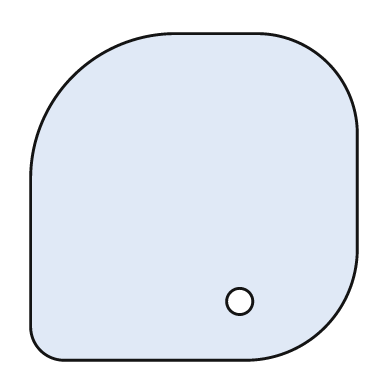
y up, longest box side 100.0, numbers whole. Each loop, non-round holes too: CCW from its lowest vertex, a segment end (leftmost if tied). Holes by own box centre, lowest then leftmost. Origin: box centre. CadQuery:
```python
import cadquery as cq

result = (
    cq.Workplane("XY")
    .moveTo(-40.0, -50.0)
    .lineTo(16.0, -50.0)
    .threePointArc((40.0, -40.0), (50.0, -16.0))
    .lineTo(50.0, 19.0)
    .threePointArc((41.0, 41.0), (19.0, 50.0))
    .lineTo(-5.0, 50.0)
    .threePointArc((-37.0, 37.0), (-50.0, 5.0))
    .lineTo(-50.0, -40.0)
    .threePointArc((-47.0, -47.0), (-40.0, -50.0))
    .close()
    .moveTo(14.0, -32.0)
    .circle(4.0)
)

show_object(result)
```